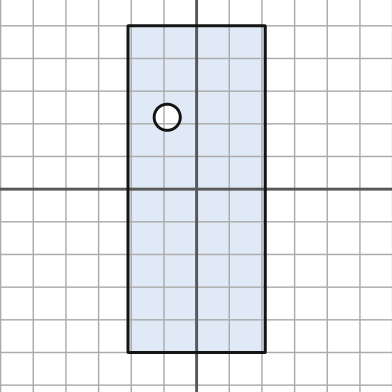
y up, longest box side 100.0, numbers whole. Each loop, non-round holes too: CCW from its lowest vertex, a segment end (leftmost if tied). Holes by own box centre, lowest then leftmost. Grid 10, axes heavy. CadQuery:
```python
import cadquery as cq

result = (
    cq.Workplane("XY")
    .moveTo(-21.0, -50.0)
    .lineTo(21.0, -50.0)
    .lineTo(21.0, 50.0)
    .lineTo(-21.0, 50.0)
    .close()
    .moveTo(-9.0, 22.0)
    .circle(4.0)
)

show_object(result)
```